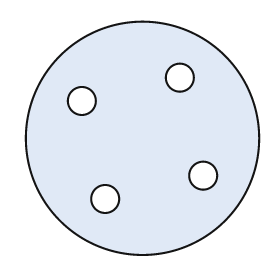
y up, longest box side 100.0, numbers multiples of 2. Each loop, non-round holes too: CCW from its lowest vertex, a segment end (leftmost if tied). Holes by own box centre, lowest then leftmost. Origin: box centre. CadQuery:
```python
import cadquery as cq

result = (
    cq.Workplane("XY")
    .moveTo(0.0, 0.0)
    .circle(50.0)
    .moveTo(-16.0, -26.0)
    .circle(6.0)
    .moveTo(26.0, -16.0)
    .circle(6.0)
    .moveTo(-26.0, 16.0)
    .circle(6.0)
    .moveTo(16.0, 26.0)
    .circle(6.0)
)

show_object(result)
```